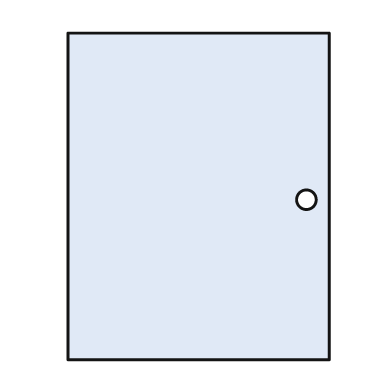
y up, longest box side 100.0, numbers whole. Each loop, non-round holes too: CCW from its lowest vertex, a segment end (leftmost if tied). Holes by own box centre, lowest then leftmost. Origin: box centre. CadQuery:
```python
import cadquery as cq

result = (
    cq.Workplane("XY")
    .moveTo(-40.0, -50.0)
    .lineTo(40.0, -50.0)
    .lineTo(40.0, 50.0)
    .lineTo(-40.0, 50.0)
    .close()
    .moveTo(33.0, -1.0)
    .circle(3.0)
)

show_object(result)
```